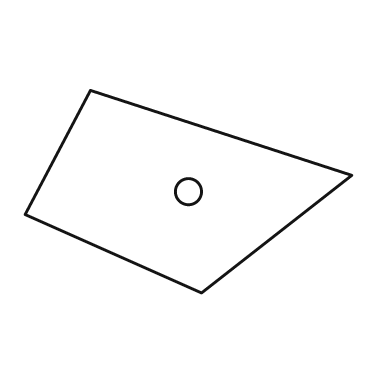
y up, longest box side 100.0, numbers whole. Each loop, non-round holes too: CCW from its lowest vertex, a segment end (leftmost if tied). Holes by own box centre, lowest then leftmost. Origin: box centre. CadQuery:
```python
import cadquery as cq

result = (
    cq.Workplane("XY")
    .moveTo(4.0, -31.0)
    .lineTo(50.0, 5.0)
    .lineTo(-30.0, 31.0)
    .lineTo(-50.0, -7.0)
    .close()
    .moveTo(0.0, 0.0)
    .circle(4.0)
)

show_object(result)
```